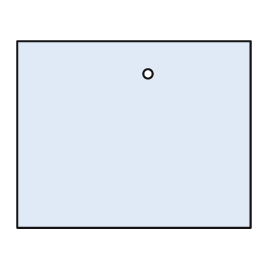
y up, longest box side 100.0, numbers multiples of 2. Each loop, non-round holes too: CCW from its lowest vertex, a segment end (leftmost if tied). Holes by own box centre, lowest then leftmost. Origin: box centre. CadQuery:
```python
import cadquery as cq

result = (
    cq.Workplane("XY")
    .moveTo(-50.0, -40.0)
    .lineTo(50.0, -40.0)
    .lineTo(50.0, 40.0)
    .lineTo(-50.0, 40.0)
    .close()
    .moveTo(6.0, 26.0)
    .circle(2.0)
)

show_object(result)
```